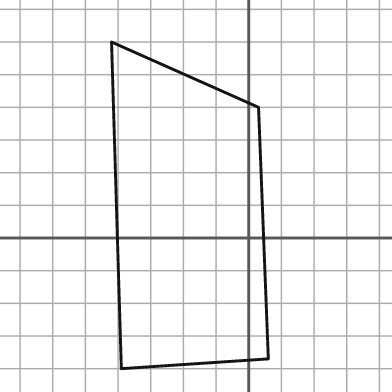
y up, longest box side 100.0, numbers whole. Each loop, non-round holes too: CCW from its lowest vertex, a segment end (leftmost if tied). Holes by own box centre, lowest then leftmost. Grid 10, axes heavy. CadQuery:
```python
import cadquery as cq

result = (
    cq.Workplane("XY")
    .moveTo(-39.0, -40.0)
    .lineTo(6.0, -37.0)
    .lineTo(3.0, 40.0)
    .lineTo(-42.0, 60.0)
    .close()
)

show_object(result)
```